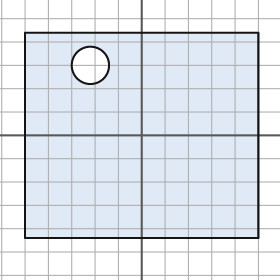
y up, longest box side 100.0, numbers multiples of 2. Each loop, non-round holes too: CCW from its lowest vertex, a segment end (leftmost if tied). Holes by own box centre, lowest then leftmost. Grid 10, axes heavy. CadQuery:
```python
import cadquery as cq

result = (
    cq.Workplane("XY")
    .moveTo(-50.0, -44.0)
    .lineTo(50.0, -44.0)
    .lineTo(50.0, 44.0)
    .lineTo(-50.0, 44.0)
    .close()
    .moveTo(-22.0, 30.0)
    .circle(8.0)
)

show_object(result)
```